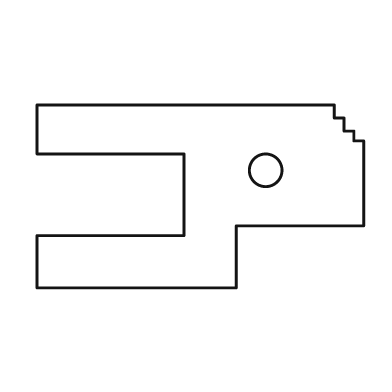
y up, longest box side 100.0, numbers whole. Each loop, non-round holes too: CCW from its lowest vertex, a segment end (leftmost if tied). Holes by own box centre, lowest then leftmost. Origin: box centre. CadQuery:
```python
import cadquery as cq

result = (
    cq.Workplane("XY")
    .moveTo(-50.0, -28.0)
    .lineTo(11.0, -28.0)
    .lineTo(11.0, -9.0)
    .lineTo(50.0, -9.0)
    .lineTo(50.0, 17.0)
    .lineTo(47.0, 17.0)
    .lineTo(47.0, 20.0)
    .lineTo(44.0, 20.0)
    .lineTo(44.0, 24.0)
    .lineTo(41.0, 24.0)
    .lineTo(41.0, 28.0)
    .lineTo(-50.0, 28.0)
    .lineTo(-50.0, 13.0)
    .lineTo(-5.0, 13.0)
    .lineTo(-5.0, -12.0)
    .lineTo(-50.0, -12.0)
    .close()
    .moveTo(20.0, 8.0)
    .circle(5.0)
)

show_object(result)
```